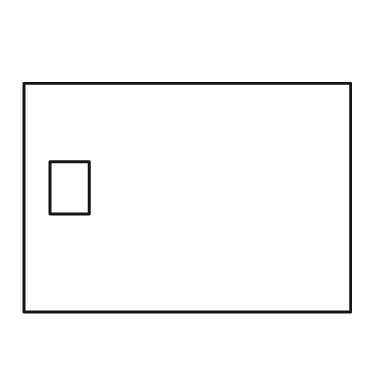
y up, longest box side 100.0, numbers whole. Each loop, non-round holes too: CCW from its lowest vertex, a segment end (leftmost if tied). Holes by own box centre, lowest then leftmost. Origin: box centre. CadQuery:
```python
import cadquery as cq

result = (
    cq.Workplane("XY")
    .moveTo(-50.0, -35.0)
    .lineTo(50.0, -35.0)
    .lineTo(50.0, 35.0)
    .lineTo(-50.0, 35.0)
    .close()
    .moveTo(-42.0, -5.0)
    .lineTo(-30.0, -5.0)
    .lineTo(-30.0, 11.0)
    .lineTo(-42.0, 11.0)
    .close()
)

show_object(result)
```